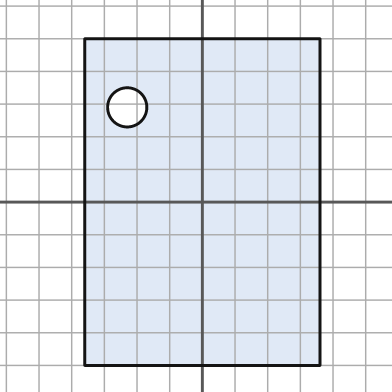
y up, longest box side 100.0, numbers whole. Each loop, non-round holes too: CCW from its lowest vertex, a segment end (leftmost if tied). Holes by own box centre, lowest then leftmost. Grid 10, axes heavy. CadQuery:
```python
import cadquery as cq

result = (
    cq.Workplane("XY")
    .moveTo(-36.0, -50.0)
    .lineTo(36.0, -50.0)
    .lineTo(36.0, 50.0)
    .lineTo(-36.0, 50.0)
    .close()
    .moveTo(-23.0, 29.0)
    .circle(6.0)
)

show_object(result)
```